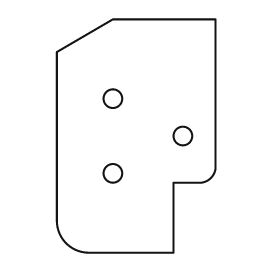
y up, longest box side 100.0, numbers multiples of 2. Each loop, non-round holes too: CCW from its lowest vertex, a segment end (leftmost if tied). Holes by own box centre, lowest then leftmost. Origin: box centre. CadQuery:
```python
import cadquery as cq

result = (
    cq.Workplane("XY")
    .moveTo(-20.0, -50.0)
    .lineTo(16.0, -50.0)
    .lineTo(16.0, -20.0)
    .lineTo(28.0, -20.0)
    .threePointArc((32.0, -18.0), (34.0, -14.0))
    .lineTo(34.0, 50.0)
    .lineTo(-10.0, 50.0)
    .lineTo(-34.0, 36.0)
    .lineTo(-34.0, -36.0)
    .threePointArc((-30.0, -46.0), (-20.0, -50.0))
    .close()
    .moveTo(-10.0, -16.0)
    .circle(4.0)
    .moveTo(20.0, 0.0)
    .circle(4.0)
    .moveTo(-10.0, 16.0)
    .circle(4.0)
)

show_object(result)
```